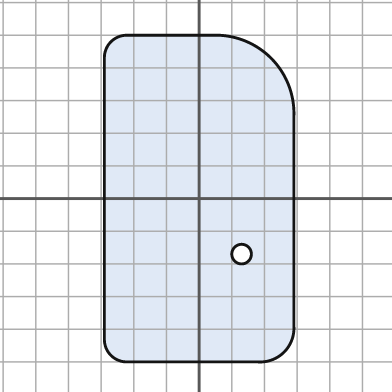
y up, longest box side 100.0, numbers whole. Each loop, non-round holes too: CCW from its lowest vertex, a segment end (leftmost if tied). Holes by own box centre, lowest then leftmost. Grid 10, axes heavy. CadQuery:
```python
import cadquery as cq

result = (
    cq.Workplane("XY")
    .moveTo(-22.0, -50.0)
    .lineTo(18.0, -50.0)
    .threePointArc((26.0, -47.0), (29.0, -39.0))
    .lineTo(29.0, 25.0)
    .threePointArc((22.0, 43.0), (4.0, 50.0))
    .lineTo(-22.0, 50.0)
    .threePointArc((-27.0, 48.0), (-29.0, 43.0))
    .lineTo(-29.0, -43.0)
    .threePointArc((-27.0, -48.0), (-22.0, -50.0))
    .close()
    .moveTo(13.0, -17.0)
    .circle(3.0)
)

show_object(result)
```